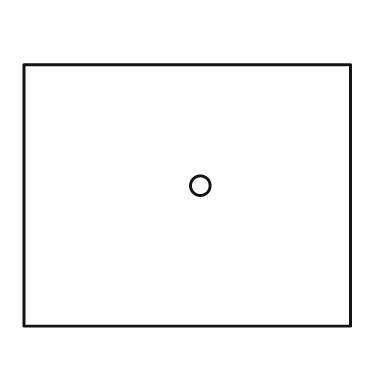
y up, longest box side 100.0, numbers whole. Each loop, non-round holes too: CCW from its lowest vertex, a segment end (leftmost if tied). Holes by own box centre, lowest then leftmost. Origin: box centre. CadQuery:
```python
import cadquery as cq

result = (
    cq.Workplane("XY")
    .moveTo(-50.0, -40.0)
    .lineTo(50.0, -40.0)
    .lineTo(50.0, 40.0)
    .lineTo(-50.0, 40.0)
    .close()
    .moveTo(4.0, 3.0)
    .circle(3.0)
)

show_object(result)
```